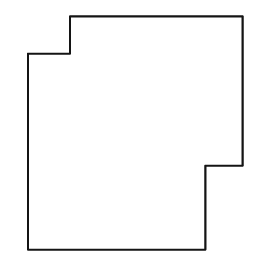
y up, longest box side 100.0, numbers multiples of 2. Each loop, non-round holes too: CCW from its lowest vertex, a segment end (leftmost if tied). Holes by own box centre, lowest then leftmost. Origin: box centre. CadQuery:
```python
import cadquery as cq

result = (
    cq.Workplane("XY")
    .moveTo(-46.0, -50.0)
    .lineTo(30.0, -50.0)
    .lineTo(30.0, -14.0)
    .lineTo(46.0, -14.0)
    .lineTo(46.0, 50.0)
    .lineTo(-28.0, 50.0)
    .lineTo(-28.0, 34.0)
    .lineTo(-46.0, 34.0)
    .close()
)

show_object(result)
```